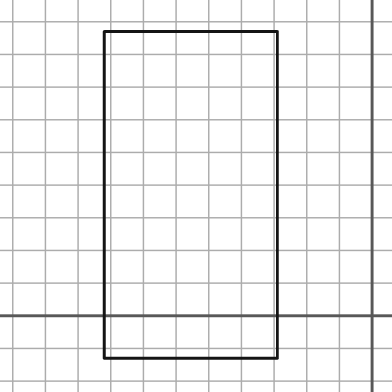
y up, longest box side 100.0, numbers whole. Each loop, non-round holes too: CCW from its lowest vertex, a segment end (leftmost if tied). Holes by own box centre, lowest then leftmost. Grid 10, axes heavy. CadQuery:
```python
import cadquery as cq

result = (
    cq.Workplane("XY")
    .moveTo(-82.0, -13.0)
    .lineTo(-29.0, -13.0)
    .lineTo(-29.0, 87.0)
    .lineTo(-82.0, 87.0)
    .close()
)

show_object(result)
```